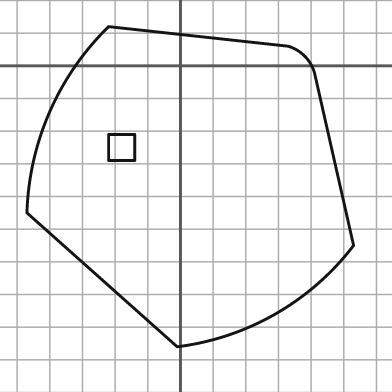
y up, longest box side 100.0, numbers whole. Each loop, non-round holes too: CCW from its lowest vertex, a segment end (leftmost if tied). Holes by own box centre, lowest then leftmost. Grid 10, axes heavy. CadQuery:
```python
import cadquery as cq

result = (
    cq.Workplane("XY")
    .moveTo(-1.0, -86.0)
    .threePointArc((29.0, -76.0), (53.0, -55.0))
    .lineTo(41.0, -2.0)
    .threePointArc((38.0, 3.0), (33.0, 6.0))
    .lineTo(-22.0, 12.0)
    .threePointArc((-40.0, -14.0), (-47.0, -45.0))
    .close()
    .moveTo(-22.0, -29.0)
    .lineTo(-14.0, -29.0)
    .lineTo(-14.0, -21.0)
    .lineTo(-22.0, -21.0)
    .close()
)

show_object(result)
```